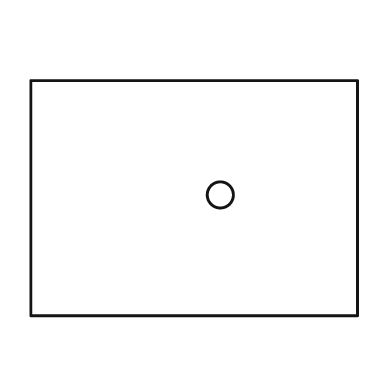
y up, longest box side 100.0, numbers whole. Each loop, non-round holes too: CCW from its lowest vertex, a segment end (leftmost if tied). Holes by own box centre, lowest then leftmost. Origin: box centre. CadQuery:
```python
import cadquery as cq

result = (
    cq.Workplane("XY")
    .moveTo(-50.0, -36.0)
    .lineTo(50.0, -36.0)
    .lineTo(50.0, 36.0)
    .lineTo(-50.0, 36.0)
    .close()
    .moveTo(8.0, 1.0)
    .circle(4.0)
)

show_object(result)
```